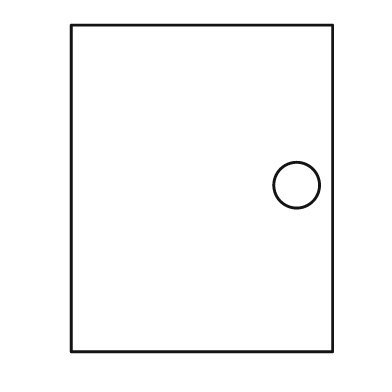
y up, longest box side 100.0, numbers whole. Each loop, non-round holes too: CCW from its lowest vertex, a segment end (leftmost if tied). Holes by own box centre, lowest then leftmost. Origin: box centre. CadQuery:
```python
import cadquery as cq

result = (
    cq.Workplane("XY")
    .moveTo(-40.0, -50.0)
    .lineTo(40.0, -50.0)
    .lineTo(40.0, 50.0)
    .lineTo(-40.0, 50.0)
    .close()
    .moveTo(29.0, 1.0)
    .circle(7.0)
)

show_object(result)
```